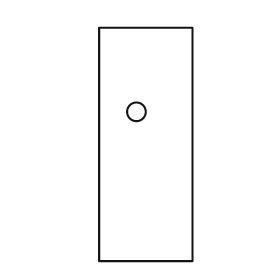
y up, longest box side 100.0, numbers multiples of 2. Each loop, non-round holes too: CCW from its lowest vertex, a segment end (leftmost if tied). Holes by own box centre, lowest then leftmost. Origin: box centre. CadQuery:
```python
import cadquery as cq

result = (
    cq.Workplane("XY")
    .moveTo(-20.0, -50.0)
    .lineTo(20.0, -50.0)
    .lineTo(20.0, 50.0)
    .lineTo(-20.0, 50.0)
    .close()
    .moveTo(-4.0, 14.0)
    .circle(4.0)
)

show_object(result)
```